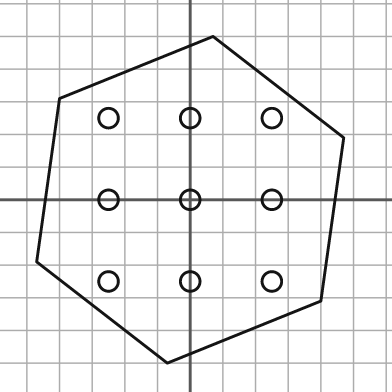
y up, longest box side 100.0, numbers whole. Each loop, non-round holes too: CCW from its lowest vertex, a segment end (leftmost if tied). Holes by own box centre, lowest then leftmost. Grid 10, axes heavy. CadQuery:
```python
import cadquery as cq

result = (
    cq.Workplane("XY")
    .moveTo(-7.0, -50.0)
    .lineTo(40.0, -31.0)
    .lineTo(47.0, 19.0)
    .lineTo(7.0, 50.0)
    .lineTo(-40.0, 31.0)
    .lineTo(-47.0, -19.0)
    .close()
    .moveTo(-25.0, -25.0)
    .circle(3.0)
    .moveTo(0.0, -25.0)
    .circle(3.0)
    .moveTo(25.0, -25.0)
    .circle(3.0)
    .moveTo(-25.0, 0.0)
    .circle(3.0)
    .moveTo(0.0, 0.0)
    .circle(3.0)
    .moveTo(25.0, 0.0)
    .circle(3.0)
    .moveTo(-25.0, 25.0)
    .circle(3.0)
    .moveTo(0.0, 25.0)
    .circle(3.0)
    .moveTo(25.0, 25.0)
    .circle(3.0)
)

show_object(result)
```